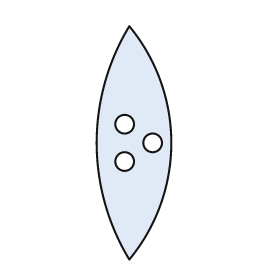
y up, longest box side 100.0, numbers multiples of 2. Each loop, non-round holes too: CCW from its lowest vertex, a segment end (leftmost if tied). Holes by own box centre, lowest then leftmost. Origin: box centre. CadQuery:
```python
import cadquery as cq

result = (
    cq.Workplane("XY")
    .moveTo(-2.0, -50.0)
    .threePointArc((16.0, 0.0), (-2.0, 50.0))
    .threePointArc((-16.0, 0.0), (-2.0, -50.0))
    .close()
    .moveTo(-4.0, -8.0)
    .circle(4.0)
    .moveTo(8.0, 0.0)
    .circle(4.0)
    .moveTo(-4.0, 8.0)
    .circle(4.0)
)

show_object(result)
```